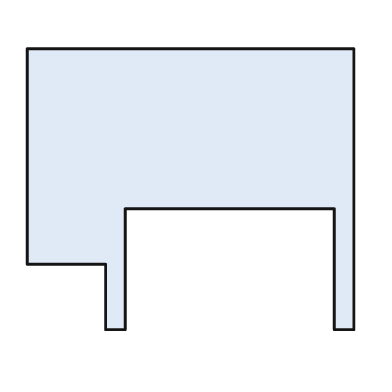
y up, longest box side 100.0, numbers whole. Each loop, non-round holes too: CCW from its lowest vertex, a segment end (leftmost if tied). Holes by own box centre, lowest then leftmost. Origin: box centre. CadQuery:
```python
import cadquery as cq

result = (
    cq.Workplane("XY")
    .moveTo(-26.0, -43.0)
    .lineTo(-20.0, -43.0)
    .lineTo(-20.0, -6.0)
    .lineTo(44.0, -6.0)
    .lineTo(44.0, -43.0)
    .lineTo(50.0, -43.0)
    .lineTo(50.0, 43.0)
    .lineTo(-50.0, 43.0)
    .lineTo(-50.0, -23.0)
    .lineTo(-26.0, -23.0)
    .close()
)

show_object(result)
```